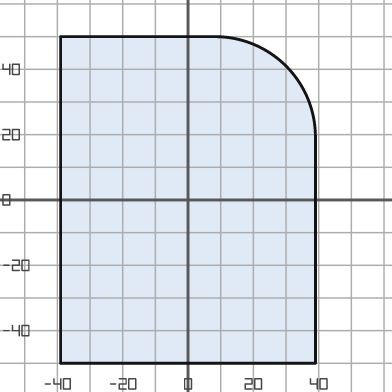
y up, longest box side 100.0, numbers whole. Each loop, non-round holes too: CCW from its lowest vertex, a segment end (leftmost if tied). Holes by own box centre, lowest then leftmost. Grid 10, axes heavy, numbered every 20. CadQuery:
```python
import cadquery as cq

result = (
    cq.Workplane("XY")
    .moveTo(-39.0, -50.0)
    .lineTo(39.0, -50.0)
    .lineTo(39.0, 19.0)
    .threePointArc((30.0, 41.0), (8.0, 50.0))
    .lineTo(-39.0, 50.0)
    .close()
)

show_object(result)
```